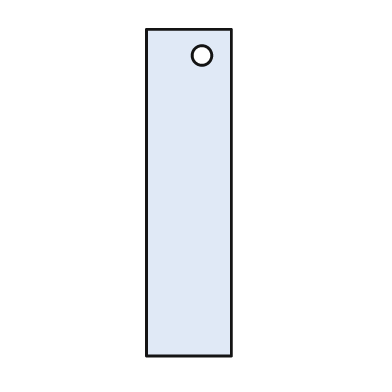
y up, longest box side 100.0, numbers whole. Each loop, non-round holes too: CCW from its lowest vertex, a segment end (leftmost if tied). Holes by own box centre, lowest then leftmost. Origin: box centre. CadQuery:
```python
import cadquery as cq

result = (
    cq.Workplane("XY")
    .moveTo(-13.0, -50.0)
    .lineTo(13.0, -50.0)
    .lineTo(13.0, 50.0)
    .lineTo(-13.0, 50.0)
    .close()
    .moveTo(4.0, 42.0)
    .circle(3.0)
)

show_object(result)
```